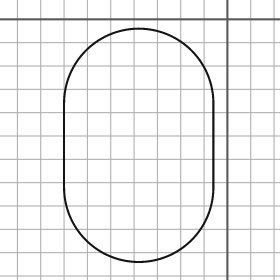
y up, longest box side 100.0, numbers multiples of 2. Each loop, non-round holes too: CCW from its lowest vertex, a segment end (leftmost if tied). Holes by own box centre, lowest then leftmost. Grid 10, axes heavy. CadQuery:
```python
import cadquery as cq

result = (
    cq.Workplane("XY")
    .moveTo(-70.0, -72.0)
    .threePointArc((-38.0, -104.0), (-6.0, -72.0))
    .lineTo(-6.0, -36.0)
    .threePointArc((-38.0, -4.0), (-70.0, -36.0))
    .close()
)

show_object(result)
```